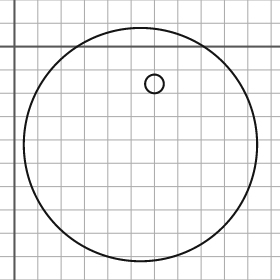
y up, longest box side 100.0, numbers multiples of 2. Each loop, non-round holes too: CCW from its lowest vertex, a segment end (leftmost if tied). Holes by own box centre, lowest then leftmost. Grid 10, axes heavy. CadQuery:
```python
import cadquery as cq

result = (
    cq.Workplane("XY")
    .moveTo(54.0, -42.0)
    .circle(50.0)
    .moveTo(60.0, -16.0)
    .circle(4.0)
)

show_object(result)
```